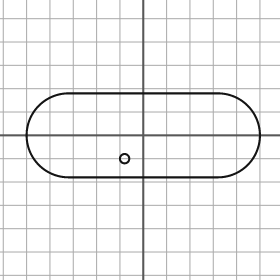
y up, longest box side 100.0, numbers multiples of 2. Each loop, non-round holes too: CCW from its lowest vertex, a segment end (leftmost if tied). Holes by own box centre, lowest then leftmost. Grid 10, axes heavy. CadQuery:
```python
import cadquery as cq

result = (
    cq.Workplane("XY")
    .moveTo(-32.0, -18.0)
    .lineTo(32.0, -18.0)
    .threePointArc((50.0, 0.0), (32.0, 18.0))
    .lineTo(-32.0, 18.0)
    .threePointArc((-50.0, 0.0), (-32.0, -18.0))
    .close()
    .moveTo(-8.0, -10.0)
    .circle(2.0)
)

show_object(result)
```